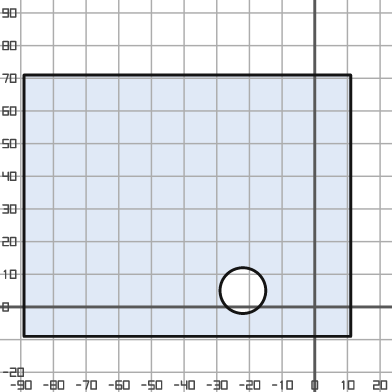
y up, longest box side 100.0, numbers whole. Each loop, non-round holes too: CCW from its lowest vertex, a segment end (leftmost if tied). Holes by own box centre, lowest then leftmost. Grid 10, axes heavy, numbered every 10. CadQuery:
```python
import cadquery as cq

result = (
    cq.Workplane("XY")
    .moveTo(-89.0, -9.0)
    .lineTo(11.0, -9.0)
    .lineTo(11.0, 71.0)
    .lineTo(-89.0, 71.0)
    .close()
    .moveTo(-22.0, 5.0)
    .circle(7.0)
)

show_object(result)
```